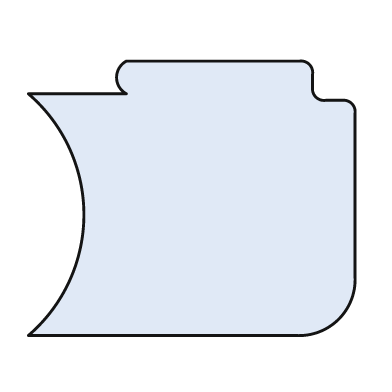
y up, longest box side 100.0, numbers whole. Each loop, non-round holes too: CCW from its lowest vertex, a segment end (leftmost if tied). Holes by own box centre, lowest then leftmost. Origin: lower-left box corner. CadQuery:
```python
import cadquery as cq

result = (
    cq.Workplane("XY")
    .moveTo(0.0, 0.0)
    .lineTo(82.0, 0.0)
    .threePointArc((95.0, 5.0), (100.0, 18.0))
    .lineTo(100.0, 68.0)
    .threePointArc((99.0, 71.0), (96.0, 72.0))
    .lineTo(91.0, 72.0)
    .threePointArc((88.0, 73.0), (87.0, 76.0))
    .lineTo(87.0, 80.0)
    .threePointArc((86.0, 83.0), (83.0, 84.0))
    .lineTo(30.0, 84.0)
    .threePointArc((27.0, 79.0), (30.0, 74.0))
    .lineTo(0.0, 74.0)
    .threePointArc((17.0, 37.0), (0.0, 0.0))
    .close()
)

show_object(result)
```